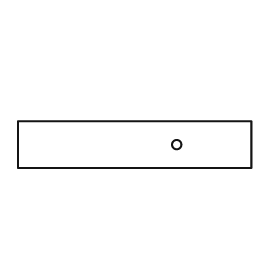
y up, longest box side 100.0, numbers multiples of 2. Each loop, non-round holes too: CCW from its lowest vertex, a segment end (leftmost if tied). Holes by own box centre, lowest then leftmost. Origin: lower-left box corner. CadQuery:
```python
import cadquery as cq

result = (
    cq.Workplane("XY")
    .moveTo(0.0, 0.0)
    .lineTo(100.0, 0.0)
    .lineTo(100.0, 20.0)
    .lineTo(0.0, 20.0)
    .close()
    .moveTo(68.0, 10.0)
    .circle(2.0)
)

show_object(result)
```